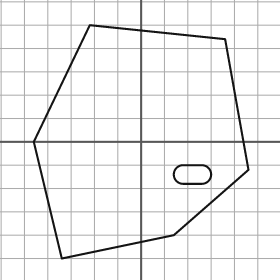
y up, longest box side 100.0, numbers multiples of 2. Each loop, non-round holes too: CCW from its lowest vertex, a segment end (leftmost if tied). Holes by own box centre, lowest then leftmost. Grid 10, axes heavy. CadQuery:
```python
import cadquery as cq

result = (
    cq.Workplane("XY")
    .moveTo(-34.0, -50.0)
    .lineTo(14.0, -40.0)
    .lineTo(46.0, -12.0)
    .lineTo(36.0, 44.0)
    .lineTo(-22.0, 50.0)
    .lineTo(-46.0, 0.0)
    .close()
    .moveTo(18.0, -18.0)
    .lineTo(26.0, -18.0)
    .threePointArc((30.0, -14.0), (26.0, -10.0))
    .lineTo(18.0, -10.0)
    .threePointArc((14.0, -14.0), (18.0, -18.0))
    .close()
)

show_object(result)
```